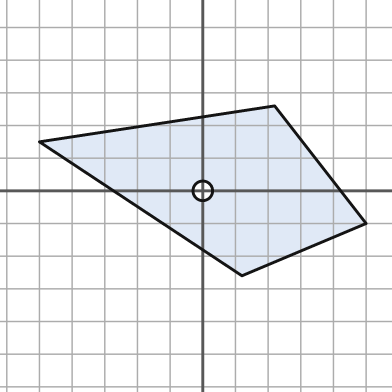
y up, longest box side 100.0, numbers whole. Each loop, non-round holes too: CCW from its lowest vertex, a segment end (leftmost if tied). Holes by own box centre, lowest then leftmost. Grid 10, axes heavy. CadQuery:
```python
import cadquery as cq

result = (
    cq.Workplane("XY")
    .moveTo(12.0, -26.0)
    .lineTo(50.0, -10.0)
    .lineTo(22.0, 26.0)
    .lineTo(-50.0, 15.0)
    .close()
    .moveTo(0.0, 0.0)
    .circle(3.0)
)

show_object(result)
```